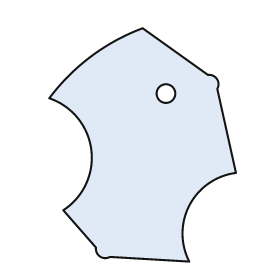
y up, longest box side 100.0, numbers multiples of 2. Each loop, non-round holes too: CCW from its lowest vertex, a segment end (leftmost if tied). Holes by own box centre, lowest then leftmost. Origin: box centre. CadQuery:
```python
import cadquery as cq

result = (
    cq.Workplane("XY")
    .moveTo(20.0, -50.0)
    .threePointArc((20.0, -26.0), (40.0, -12.0))
    .lineTo(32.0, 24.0)
    .threePointArc((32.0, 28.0), (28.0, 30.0))
    .lineTo(0.0, 50.0)
    .threePointArc((-22.0, 38.0), (-40.0, 20.0))
    .threePointArc((-22.0, -2.0), (-34.0, -28.0))
    .lineTo(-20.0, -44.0)
    .threePointArc((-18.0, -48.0), (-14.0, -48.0))
    .close()
    .moveTo(10.0, 22.0)
    .circle(4.0)
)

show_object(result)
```